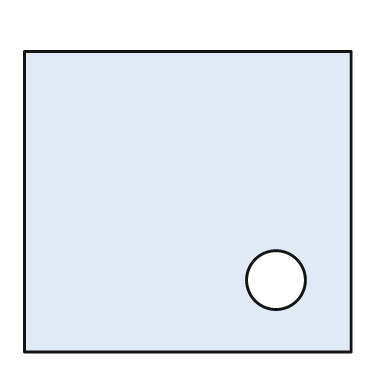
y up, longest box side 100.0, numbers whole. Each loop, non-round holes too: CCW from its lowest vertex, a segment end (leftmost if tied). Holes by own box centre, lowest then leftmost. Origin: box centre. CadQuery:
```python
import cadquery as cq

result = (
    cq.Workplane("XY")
    .moveTo(-50.0, -46.0)
    .lineTo(50.0, -46.0)
    .lineTo(50.0, 46.0)
    .lineTo(-50.0, 46.0)
    .close()
    .moveTo(27.0, -24.0)
    .circle(9.0)
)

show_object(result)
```